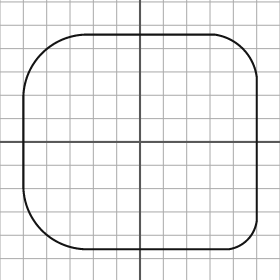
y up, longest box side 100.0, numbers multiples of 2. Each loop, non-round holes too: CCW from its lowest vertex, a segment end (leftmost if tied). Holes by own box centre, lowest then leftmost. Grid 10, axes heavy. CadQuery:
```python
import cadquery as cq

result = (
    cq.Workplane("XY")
    .moveTo(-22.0, -46.0)
    .lineTo(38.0, -46.0)
    .threePointArc((46.0, -42.0), (50.0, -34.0))
    .lineTo(50.0, 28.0)
    .threePointArc((44.0, 40.0), (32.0, 46.0))
    .lineTo(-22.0, 46.0)
    .threePointArc((-42.0, 38.0), (-50.0, 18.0))
    .lineTo(-50.0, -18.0)
    .threePointArc((-42.0, -38.0), (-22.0, -46.0))
    .close()
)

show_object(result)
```